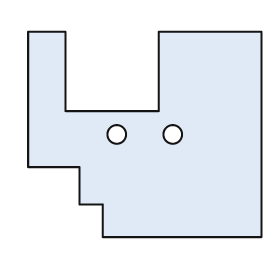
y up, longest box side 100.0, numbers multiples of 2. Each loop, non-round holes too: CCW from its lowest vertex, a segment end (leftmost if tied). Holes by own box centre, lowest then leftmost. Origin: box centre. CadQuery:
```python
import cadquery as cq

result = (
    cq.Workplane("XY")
    .moveTo(-18.0, -44.0)
    .lineTo(50.0, -44.0)
    .lineTo(50.0, 44.0)
    .lineTo(6.0, 44.0)
    .lineTo(6.0, 10.0)
    .lineTo(-34.0, 10.0)
    .lineTo(-34.0, 44.0)
    .lineTo(-50.0, 44.0)
    .lineTo(-50.0, -14.0)
    .lineTo(-28.0, -14.0)
    .lineTo(-28.0, -30.0)
    .lineTo(-18.0, -30.0)
    .close()
    .moveTo(-12.0, 0.0)
    .circle(4.0)
    .moveTo(12.0, 0.0)
    .circle(4.0)
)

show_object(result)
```